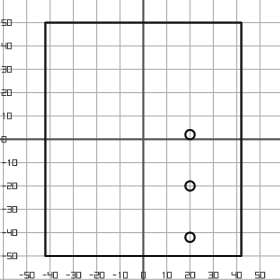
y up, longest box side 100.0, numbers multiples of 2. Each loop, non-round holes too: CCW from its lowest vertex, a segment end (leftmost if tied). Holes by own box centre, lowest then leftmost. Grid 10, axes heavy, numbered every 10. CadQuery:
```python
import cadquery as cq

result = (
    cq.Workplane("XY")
    .moveTo(-42.0, -50.0)
    .lineTo(42.0, -50.0)
    .lineTo(42.0, 50.0)
    .lineTo(-42.0, 50.0)
    .close()
    .moveTo(20.0, -42.0)
    .circle(2.0)
    .moveTo(20.0, -20.0)
    .circle(2.0)
    .moveTo(20.0, 2.0)
    .circle(2.0)
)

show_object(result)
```